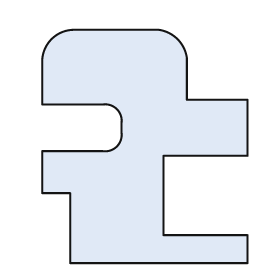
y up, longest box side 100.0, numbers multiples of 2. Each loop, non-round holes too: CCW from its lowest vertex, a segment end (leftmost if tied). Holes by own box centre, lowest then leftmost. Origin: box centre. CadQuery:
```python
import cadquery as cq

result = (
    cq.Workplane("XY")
    .moveTo(-32.0, -50.0)
    .lineTo(44.0, -50.0)
    .lineTo(44.0, -38.0)
    .lineTo(8.0, -38.0)
    .lineTo(8.0, -4.0)
    .lineTo(44.0, -4.0)
    .lineTo(44.0, 20.0)
    .lineTo(18.0, 20.0)
    .lineTo(18.0, 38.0)
    .threePointArc((14.0, 46.0), (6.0, 50.0))
    .lineTo(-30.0, 50.0)
    .threePointArc((-40.0, 46.0), (-44.0, 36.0))
    .lineTo(-44.0, 18.0)
    .lineTo(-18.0, 18.0)
    .threePointArc((-12.0, 16.0), (-10.0, 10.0))
    .lineTo(-10.0, 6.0)
    .threePointArc((-12.0, 0.0), (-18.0, -2.0))
    .lineTo(-44.0, -2.0)
    .lineTo(-44.0, -20.0)
    .lineTo(-32.0, -20.0)
    .close()
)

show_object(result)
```